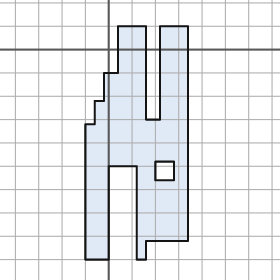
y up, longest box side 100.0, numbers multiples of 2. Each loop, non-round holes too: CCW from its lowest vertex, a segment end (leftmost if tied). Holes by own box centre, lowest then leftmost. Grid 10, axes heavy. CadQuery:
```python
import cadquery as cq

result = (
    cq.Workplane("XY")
    .moveTo(-10.0, -90.0)
    .lineTo(0.0, -90.0)
    .lineTo(0.0, -50.0)
    .lineTo(12.0, -50.0)
    .lineTo(12.0, -90.0)
    .lineTo(16.0, -90.0)
    .lineTo(16.0, -82.0)
    .lineTo(34.0, -82.0)
    .lineTo(34.0, 10.0)
    .lineTo(22.0, 10.0)
    .lineTo(22.0, -30.0)
    .lineTo(16.0, -30.0)
    .lineTo(16.0, 10.0)
    .lineTo(4.0, 10.0)
    .lineTo(4.0, -10.0)
    .lineTo(-2.0, -10.0)
    .lineTo(-2.0, -22.0)
    .lineTo(-6.0, -22.0)
    .lineTo(-6.0, -32.0)
    .lineTo(-10.0, -32.0)
    .close()
    .moveTo(20.0, -56.0)
    .lineTo(28.0, -56.0)
    .lineTo(28.0, -48.0)
    .lineTo(20.0, -48.0)
    .close()
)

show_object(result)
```